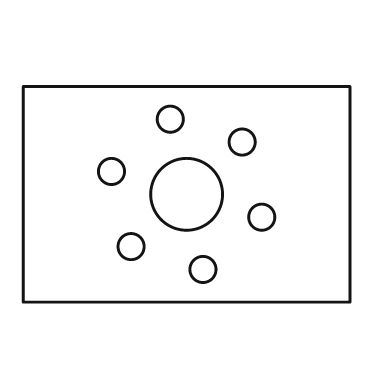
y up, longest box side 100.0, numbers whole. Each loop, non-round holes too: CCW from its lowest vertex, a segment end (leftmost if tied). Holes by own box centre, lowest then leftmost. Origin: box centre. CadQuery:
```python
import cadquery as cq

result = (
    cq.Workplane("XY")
    .moveTo(-50.0, -33.0)
    .lineTo(50.0, -33.0)
    .lineTo(50.0, 33.0)
    .lineTo(-50.0, 33.0)
    .close()
    .moveTo(5.0, -23.0)
    .circle(4.0)
    .moveTo(-17.0, -16.0)
    .circle(4.0)
    .moveTo(23.0, -7.0)
    .circle(4.0)
    .moveTo(0.0, 0.0)
    .circle(11.0)
    .moveTo(-23.0, 7.0)
    .circle(4.0)
    .moveTo(17.0, 16.0)
    .circle(4.0)
    .moveTo(-5.0, 23.0)
    .circle(4.0)
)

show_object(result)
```